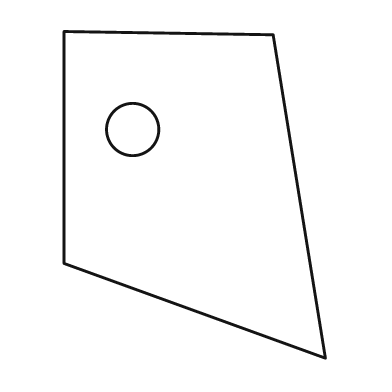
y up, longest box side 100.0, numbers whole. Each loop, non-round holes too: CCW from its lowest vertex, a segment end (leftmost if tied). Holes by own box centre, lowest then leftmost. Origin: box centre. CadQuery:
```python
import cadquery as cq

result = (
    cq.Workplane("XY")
    .moveTo(40.0, -50.0)
    .lineTo(24.0, 49.0)
    .lineTo(-40.0, 50.0)
    .lineTo(-40.0, -21.0)
    .close()
    .moveTo(-19.0, 20.0)
    .circle(8.0)
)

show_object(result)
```